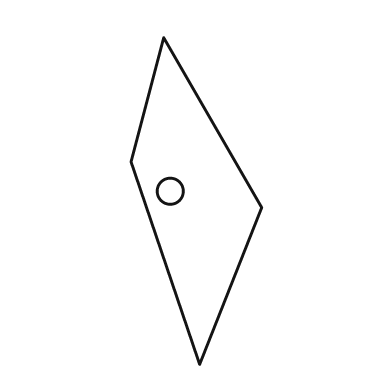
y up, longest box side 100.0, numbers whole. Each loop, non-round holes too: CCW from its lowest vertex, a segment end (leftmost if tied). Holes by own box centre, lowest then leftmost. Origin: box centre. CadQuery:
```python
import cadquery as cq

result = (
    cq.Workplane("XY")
    .moveTo(1.0, -50.0)
    .lineTo(20.0, -2.0)
    .lineTo(-10.0, 50.0)
    .lineTo(-20.0, 12.0)
    .close()
    .moveTo(-8.0, 3.0)
    .circle(4.0)
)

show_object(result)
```